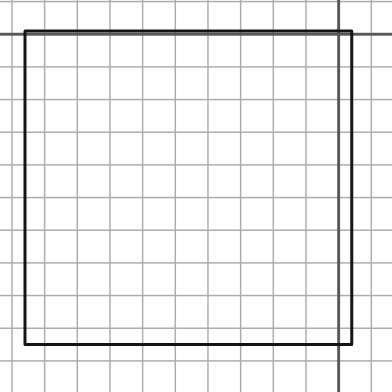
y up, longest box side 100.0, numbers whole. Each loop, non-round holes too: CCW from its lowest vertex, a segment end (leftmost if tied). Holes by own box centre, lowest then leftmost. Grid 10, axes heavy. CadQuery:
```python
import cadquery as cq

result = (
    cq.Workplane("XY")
    .moveTo(-96.0, -95.0)
    .lineTo(4.0, -95.0)
    .lineTo(4.0, 1.0)
    .lineTo(-96.0, 1.0)
    .close()
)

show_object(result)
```